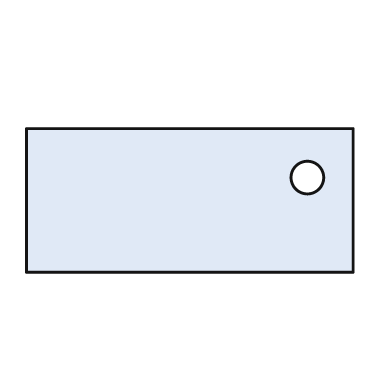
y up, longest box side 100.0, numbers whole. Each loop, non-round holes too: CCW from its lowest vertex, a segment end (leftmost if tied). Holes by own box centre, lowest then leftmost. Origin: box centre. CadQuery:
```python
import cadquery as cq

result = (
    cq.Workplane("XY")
    .moveTo(-50.0, -22.0)
    .lineTo(50.0, -22.0)
    .lineTo(50.0, 22.0)
    .lineTo(-50.0, 22.0)
    .close()
    .moveTo(36.0, 7.0)
    .circle(5.0)
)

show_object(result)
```